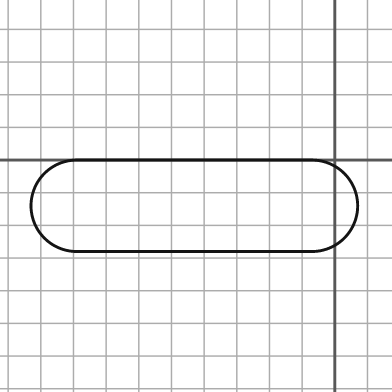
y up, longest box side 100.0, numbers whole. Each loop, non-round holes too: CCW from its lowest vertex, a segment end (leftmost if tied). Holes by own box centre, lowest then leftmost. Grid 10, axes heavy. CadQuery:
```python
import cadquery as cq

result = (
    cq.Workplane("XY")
    .moveTo(-79.0, -28.0)
    .lineTo(-7.0, -28.0)
    .threePointArc((7.0, -14.0), (-7.0, 0.0))
    .lineTo(-79.0, 0.0)
    .threePointArc((-93.0, -14.0), (-79.0, -28.0))
    .close()
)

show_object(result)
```